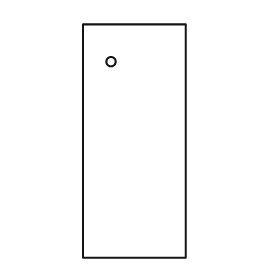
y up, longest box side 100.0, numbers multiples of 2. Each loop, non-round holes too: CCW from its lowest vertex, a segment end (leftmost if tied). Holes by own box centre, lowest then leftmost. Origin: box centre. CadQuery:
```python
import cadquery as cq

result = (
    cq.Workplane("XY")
    .moveTo(-22.0, -50.0)
    .lineTo(22.0, -50.0)
    .lineTo(22.0, 50.0)
    .lineTo(-22.0, 50.0)
    .close()
    .moveTo(-10.0, 34.0)
    .circle(2.0)
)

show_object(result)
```